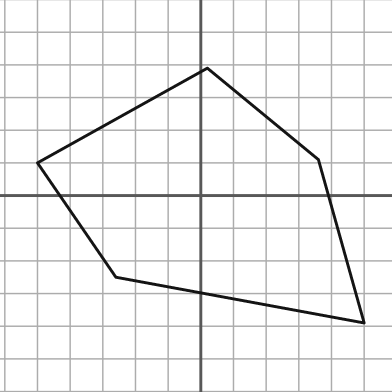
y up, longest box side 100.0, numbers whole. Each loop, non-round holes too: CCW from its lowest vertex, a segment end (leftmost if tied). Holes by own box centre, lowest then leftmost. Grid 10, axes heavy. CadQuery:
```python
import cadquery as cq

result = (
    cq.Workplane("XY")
    .moveTo(50.0, -39.0)
    .lineTo(36.0, 11.0)
    .lineTo(2.0, 39.0)
    .lineTo(-50.0, 10.0)
    .lineTo(-26.0, -25.0)
    .close()
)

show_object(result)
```